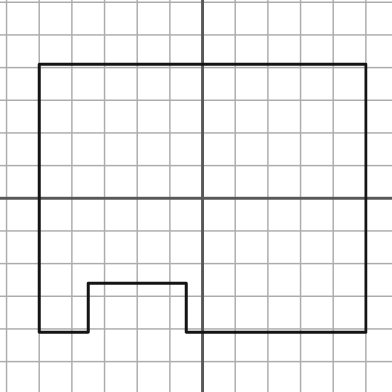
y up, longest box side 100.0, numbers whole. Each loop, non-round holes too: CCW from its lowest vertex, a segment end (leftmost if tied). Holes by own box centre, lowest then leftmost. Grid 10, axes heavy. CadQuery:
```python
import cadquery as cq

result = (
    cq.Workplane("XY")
    .moveTo(-50.0, -41.0)
    .lineTo(-35.0, -41.0)
    .lineTo(-35.0, -26.0)
    .lineTo(-5.0, -26.0)
    .lineTo(-5.0, -41.0)
    .lineTo(50.0, -41.0)
    .lineTo(50.0, 41.0)
    .lineTo(-50.0, 41.0)
    .close()
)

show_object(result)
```